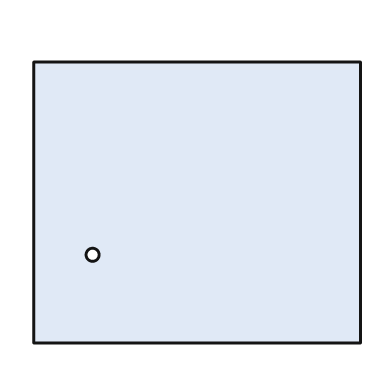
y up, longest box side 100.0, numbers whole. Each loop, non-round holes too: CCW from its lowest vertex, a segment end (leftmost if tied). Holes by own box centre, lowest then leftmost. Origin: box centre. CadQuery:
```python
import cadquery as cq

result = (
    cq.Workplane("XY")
    .moveTo(-50.0, -43.0)
    .lineTo(50.0, -43.0)
    .lineTo(50.0, 43.0)
    .lineTo(-50.0, 43.0)
    .close()
    .moveTo(-32.0, -16.0)
    .circle(2.0)
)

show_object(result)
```